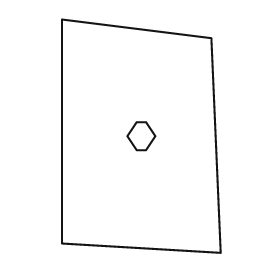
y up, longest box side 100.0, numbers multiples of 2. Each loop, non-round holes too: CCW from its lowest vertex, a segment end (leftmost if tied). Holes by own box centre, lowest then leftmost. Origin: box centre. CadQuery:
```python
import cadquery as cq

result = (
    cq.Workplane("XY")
    .moveTo(34.0, -50.0)
    .lineTo(30.0, 42.0)
    .lineTo(-34.0, 50.0)
    .lineTo(-34.0, -46.0)
    .close()
    .moveTo(-2.0, -6.0)
    .lineTo(2.0, -6.0)
    .lineTo(6.0, 0.0)
    .lineTo(2.0, 6.0)
    .lineTo(-2.0, 6.0)
    .lineTo(-6.0, 0.0)
    .close()
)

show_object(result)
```